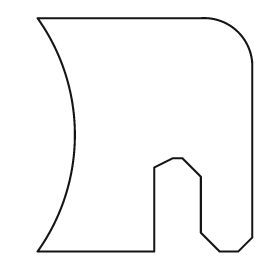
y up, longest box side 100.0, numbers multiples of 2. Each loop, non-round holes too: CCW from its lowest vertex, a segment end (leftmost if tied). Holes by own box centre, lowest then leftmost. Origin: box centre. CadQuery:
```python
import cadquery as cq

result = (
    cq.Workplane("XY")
    .moveTo(-46.0, -50.0)
    .lineTo(4.0, -50.0)
    .lineTo(4.0, -14.0)
    .lineTo(12.0, -10.0)
    .lineTo(16.0, -10.0)
    .lineTo(24.0, -18.0)
    .lineTo(24.0, -42.0)
    .lineTo(32.0, -50.0)
    .lineTo(40.0, -50.0)
    .lineTo(46.0, -44.0)
    .lineTo(46.0, 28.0)
    .threePointArc((40.0, 44.0), (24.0, 50.0))
    .lineTo(-46.0, 50.0)
    .threePointArc((-30.0, 0.0), (-46.0, -50.0))
    .close()
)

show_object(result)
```